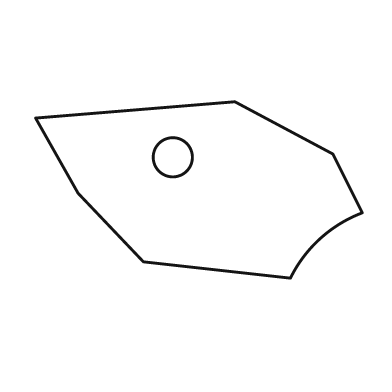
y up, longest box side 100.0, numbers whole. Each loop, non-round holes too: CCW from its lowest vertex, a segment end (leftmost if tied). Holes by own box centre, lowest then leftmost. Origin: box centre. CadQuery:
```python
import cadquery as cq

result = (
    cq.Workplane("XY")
    .moveTo(28.0, -27.0)
    .threePointArc((37.0, -15.0), (50.0, -7.0))
    .lineTo(41.0, 11.0)
    .lineTo(11.0, 27.0)
    .lineTo(-50.0, 22.0)
    .lineTo(-37.0, -1.0)
    .lineTo(-17.0, -22.0)
    .close()
    .moveTo(-8.0, 10.0)
    .circle(6.0)
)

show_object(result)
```